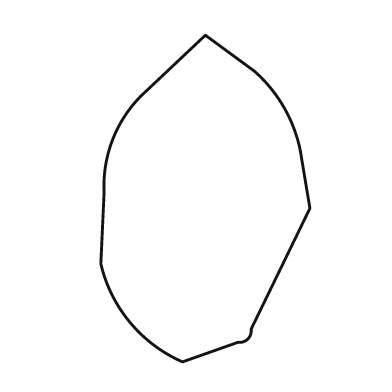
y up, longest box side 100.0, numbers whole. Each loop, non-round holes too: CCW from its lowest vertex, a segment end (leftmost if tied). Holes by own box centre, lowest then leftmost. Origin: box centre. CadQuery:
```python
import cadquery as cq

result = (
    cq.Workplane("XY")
    .moveTo(-7.0, -50.0)
    .lineTo(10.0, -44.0)
    .threePointArc((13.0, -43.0), (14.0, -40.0))
    .lineTo(32.0, -3.0)
    .lineTo(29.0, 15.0)
    .threePointArc((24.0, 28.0), (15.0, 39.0))
    .lineTo(0.0, 50.0)
    .lineTo(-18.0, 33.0)
    .threePointArc((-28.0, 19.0), (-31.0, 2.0))
    .lineTo(-32.0, -20.0)
    .threePointArc((-23.0, -38.0), (-7.0, -50.0))
    .close()
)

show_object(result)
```